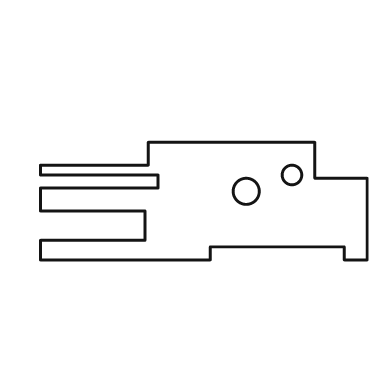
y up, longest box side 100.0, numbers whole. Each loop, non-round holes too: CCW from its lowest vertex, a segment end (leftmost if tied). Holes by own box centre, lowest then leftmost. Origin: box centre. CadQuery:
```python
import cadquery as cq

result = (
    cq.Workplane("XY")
    .moveTo(-50.0, -18.0)
    .lineTo(2.0, -18.0)
    .lineTo(2.0, -14.0)
    .lineTo(43.0, -14.0)
    .lineTo(43.0, -18.0)
    .lineTo(50.0, -18.0)
    .lineTo(50.0, 7.0)
    .lineTo(34.0, 7.0)
    .lineTo(34.0, 18.0)
    .lineTo(-17.0, 18.0)
    .lineTo(-17.0, 11.0)
    .lineTo(-50.0, 11.0)
    .lineTo(-50.0, 8.0)
    .lineTo(-14.0, 8.0)
    .lineTo(-14.0, 4.0)
    .lineTo(-50.0, 4.0)
    .lineTo(-50.0, -3.0)
    .lineTo(-18.0, -3.0)
    .lineTo(-18.0, -12.0)
    .lineTo(-50.0, -12.0)
    .close()
    .moveTo(13.0, 3.0)
    .circle(4.0)
    .moveTo(27.0, 8.0)
    .circle(3.0)
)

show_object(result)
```